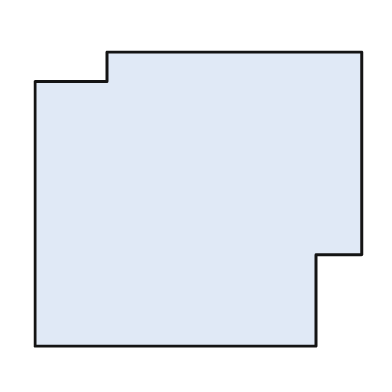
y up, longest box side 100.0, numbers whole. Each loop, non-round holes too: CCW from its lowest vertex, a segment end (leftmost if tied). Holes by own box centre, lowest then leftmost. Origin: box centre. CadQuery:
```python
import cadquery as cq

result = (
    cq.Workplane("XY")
    .moveTo(-50.0, -45.0)
    .lineTo(36.0, -45.0)
    .lineTo(36.0, -17.0)
    .lineTo(50.0, -17.0)
    .lineTo(50.0, 45.0)
    .lineTo(-28.0, 45.0)
    .lineTo(-28.0, 36.0)
    .lineTo(-50.0, 36.0)
    .close()
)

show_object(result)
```